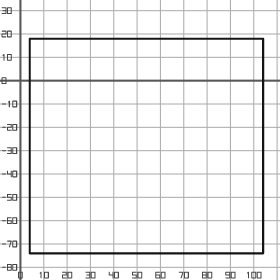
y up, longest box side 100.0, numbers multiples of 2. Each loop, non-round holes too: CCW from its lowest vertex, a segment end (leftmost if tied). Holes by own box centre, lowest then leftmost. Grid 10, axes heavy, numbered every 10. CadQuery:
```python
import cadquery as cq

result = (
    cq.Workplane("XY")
    .moveTo(4.0, -74.0)
    .lineTo(104.0, -74.0)
    .lineTo(104.0, 18.0)
    .lineTo(4.0, 18.0)
    .close()
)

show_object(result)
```